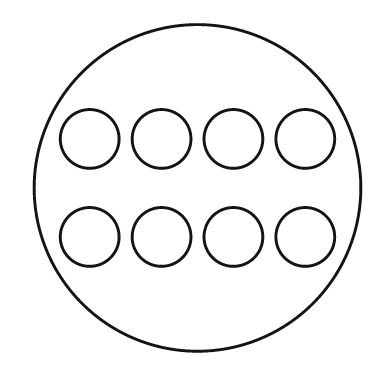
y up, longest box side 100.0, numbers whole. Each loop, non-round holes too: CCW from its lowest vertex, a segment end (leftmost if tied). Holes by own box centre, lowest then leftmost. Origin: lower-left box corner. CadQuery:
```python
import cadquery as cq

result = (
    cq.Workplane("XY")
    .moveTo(50.0, 50.0)
    .circle(50.0)
    .moveTo(17.0, 35.0)
    .circle(9.0)
    .moveTo(39.0, 35.0)
    .circle(9.0)
    .moveTo(61.0, 35.0)
    .circle(9.0)
    .moveTo(83.0, 35.0)
    .circle(9.0)
    .moveTo(17.0, 65.0)
    .circle(9.0)
    .moveTo(39.0, 65.0)
    .circle(9.0)
    .moveTo(61.0, 65.0)
    .circle(9.0)
    .moveTo(83.0, 65.0)
    .circle(9.0)
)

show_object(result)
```